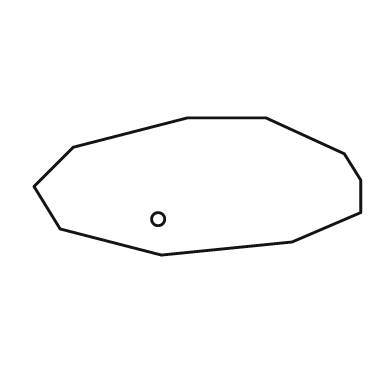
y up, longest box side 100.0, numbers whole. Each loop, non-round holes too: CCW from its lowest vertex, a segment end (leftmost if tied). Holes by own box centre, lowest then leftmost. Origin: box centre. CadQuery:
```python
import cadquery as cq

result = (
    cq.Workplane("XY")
    .moveTo(-11.0, -21.0)
    .lineTo(29.0, -17.0)
    .lineTo(50.0, -8.0)
    .lineTo(50.0, 2.0)
    .lineTo(45.0, 10.0)
    .lineTo(21.0, 21.0)
    .lineTo(-3.0, 21.0)
    .lineTo(-38.0, 12.0)
    .lineTo(-50.0, 0.0)
    .lineTo(-42.0, -13.0)
    .close()
    .moveTo(-12.0, -10.0)
    .circle(2.0)
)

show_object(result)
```